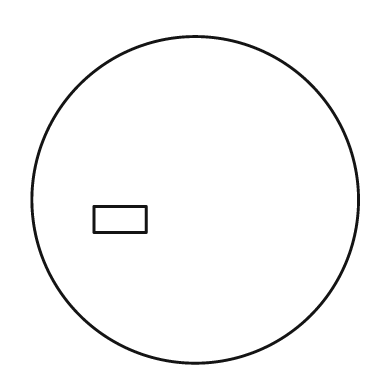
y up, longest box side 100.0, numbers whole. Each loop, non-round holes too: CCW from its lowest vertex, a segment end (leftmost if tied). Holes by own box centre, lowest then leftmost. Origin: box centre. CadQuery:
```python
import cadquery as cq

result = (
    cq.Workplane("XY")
    .moveTo(0.0, 0.0)
    .circle(50.0)
    .moveTo(-31.0, -10.0)
    .lineTo(-15.0, -10.0)
    .lineTo(-15.0, -2.0)
    .lineTo(-31.0, -2.0)
    .close()
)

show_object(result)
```